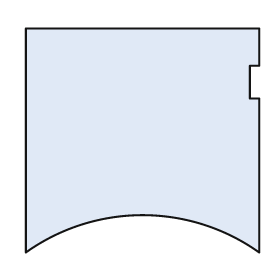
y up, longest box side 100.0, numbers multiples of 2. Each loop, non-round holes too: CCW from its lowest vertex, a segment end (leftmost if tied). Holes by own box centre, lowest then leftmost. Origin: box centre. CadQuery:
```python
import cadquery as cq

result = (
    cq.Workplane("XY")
    .moveTo(-50.0, -48.0)
    .threePointArc((0.0, -32.0), (50.0, -48.0))
    .lineTo(50.0, 18.0)
    .lineTo(46.0, 18.0)
    .lineTo(46.0, 32.0)
    .lineTo(50.0, 32.0)
    .lineTo(50.0, 48.0)
    .lineTo(-50.0, 48.0)
    .close()
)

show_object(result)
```